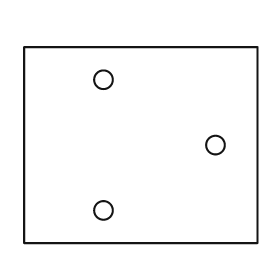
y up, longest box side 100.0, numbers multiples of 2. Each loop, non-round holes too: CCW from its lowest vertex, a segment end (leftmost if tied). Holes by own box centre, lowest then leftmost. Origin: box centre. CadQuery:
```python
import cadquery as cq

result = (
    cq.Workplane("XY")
    .moveTo(-50.0, -42.0)
    .lineTo(50.0, -42.0)
    .lineTo(50.0, 42.0)
    .lineTo(-50.0, 42.0)
    .close()
    .moveTo(-16.0, -28.0)
    .circle(4.0)
    .moveTo(32.0, 0.0)
    .circle(4.0)
    .moveTo(-16.0, 28.0)
    .circle(4.0)
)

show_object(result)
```